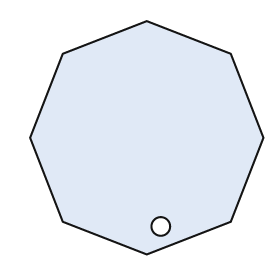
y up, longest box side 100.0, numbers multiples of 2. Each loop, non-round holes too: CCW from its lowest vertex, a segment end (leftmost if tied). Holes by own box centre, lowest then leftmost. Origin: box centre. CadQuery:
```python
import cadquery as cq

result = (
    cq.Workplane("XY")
    .moveTo(0.0, -50.0)
    .lineTo(36.0, -36.0)
    .lineTo(50.0, 0.0)
    .lineTo(36.0, 36.0)
    .lineTo(0.0, 50.0)
    .lineTo(-36.0, 36.0)
    .lineTo(-50.0, 0.0)
    .lineTo(-36.0, -36.0)
    .close()
    .moveTo(6.0, -38.0)
    .circle(4.0)
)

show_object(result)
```